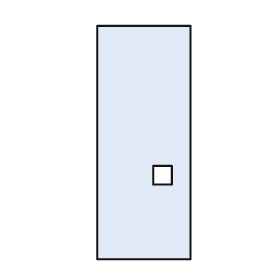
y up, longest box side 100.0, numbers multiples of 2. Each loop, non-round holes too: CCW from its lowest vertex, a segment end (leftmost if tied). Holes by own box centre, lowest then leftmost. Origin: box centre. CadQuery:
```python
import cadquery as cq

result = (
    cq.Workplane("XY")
    .moveTo(-20.0, -50.0)
    .lineTo(20.0, -50.0)
    .lineTo(20.0, 50.0)
    .lineTo(-20.0, 50.0)
    .close()
    .moveTo(4.0, -18.0)
    .lineTo(12.0, -18.0)
    .lineTo(12.0, -10.0)
    .lineTo(4.0, -10.0)
    .close()
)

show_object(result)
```